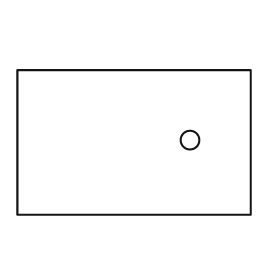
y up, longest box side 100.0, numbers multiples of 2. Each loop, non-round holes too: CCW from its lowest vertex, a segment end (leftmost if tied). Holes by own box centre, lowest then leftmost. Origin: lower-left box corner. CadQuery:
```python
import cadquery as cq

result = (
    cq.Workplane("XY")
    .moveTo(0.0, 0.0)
    .lineTo(100.0, 0.0)
    .lineTo(100.0, 62.0)
    .lineTo(0.0, 62.0)
    .close()
    .moveTo(74.0, 32.0)
    .circle(4.0)
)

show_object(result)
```